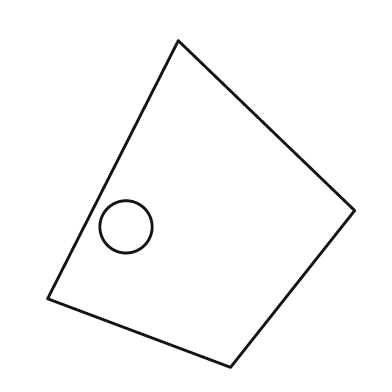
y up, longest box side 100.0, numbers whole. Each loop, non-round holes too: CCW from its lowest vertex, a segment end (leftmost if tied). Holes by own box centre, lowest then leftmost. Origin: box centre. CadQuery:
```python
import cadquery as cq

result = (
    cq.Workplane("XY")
    .moveTo(9.0, -50.0)
    .lineTo(47.0, -2.0)
    .lineTo(-7.0, 50.0)
    .lineTo(-47.0, -29.0)
    .close()
    .moveTo(-23.0, -7.0)
    .circle(8.0)
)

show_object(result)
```